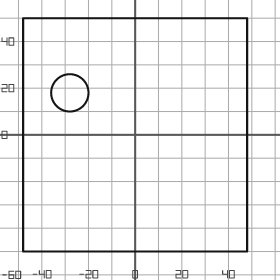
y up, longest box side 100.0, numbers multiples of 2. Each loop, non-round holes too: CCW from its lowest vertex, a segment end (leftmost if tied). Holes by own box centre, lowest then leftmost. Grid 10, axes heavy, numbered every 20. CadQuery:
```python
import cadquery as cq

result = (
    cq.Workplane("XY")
    .moveTo(-48.0, -50.0)
    .lineTo(48.0, -50.0)
    .lineTo(48.0, 50.0)
    .lineTo(-48.0, 50.0)
    .close()
    .moveTo(-28.0, 18.0)
    .circle(8.0)
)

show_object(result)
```